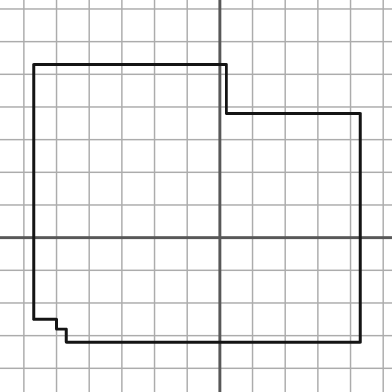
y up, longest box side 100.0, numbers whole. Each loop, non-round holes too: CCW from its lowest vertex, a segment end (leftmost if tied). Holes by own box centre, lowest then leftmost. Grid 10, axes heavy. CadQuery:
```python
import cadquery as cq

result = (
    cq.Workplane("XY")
    .moveTo(-47.0, -32.0)
    .lineTo(43.0, -32.0)
    .lineTo(43.0, 38.0)
    .lineTo(2.0, 38.0)
    .lineTo(2.0, 53.0)
    .lineTo(-57.0, 53.0)
    .lineTo(-57.0, -25.0)
    .lineTo(-50.0, -25.0)
    .lineTo(-50.0, -28.0)
    .lineTo(-47.0, -28.0)
    .close()
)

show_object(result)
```